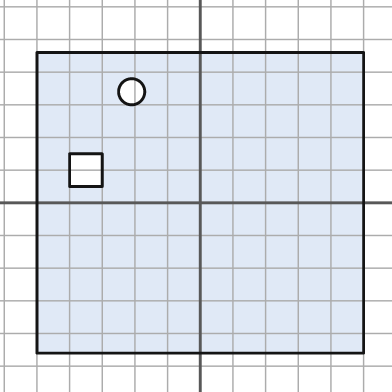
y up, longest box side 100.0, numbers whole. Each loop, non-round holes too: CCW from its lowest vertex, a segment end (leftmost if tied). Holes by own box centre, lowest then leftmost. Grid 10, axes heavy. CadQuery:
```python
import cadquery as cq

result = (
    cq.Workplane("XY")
    .moveTo(-50.0, -46.0)
    .lineTo(50.0, -46.0)
    .lineTo(50.0, 46.0)
    .lineTo(-50.0, 46.0)
    .close()
    .moveTo(-40.0, 5.0)
    .lineTo(-30.0, 5.0)
    .lineTo(-30.0, 15.0)
    .lineTo(-40.0, 15.0)
    .close()
    .moveTo(-21.0, 34.0)
    .circle(4.0)
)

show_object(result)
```